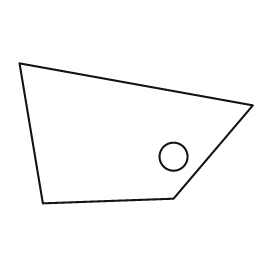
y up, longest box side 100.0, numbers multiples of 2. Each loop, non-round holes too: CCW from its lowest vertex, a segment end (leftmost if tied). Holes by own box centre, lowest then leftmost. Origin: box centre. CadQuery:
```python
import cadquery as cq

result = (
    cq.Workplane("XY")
    .moveTo(-40.0, -30.0)
    .lineTo(16.0, -28.0)
    .lineTo(50.0, 12.0)
    .lineTo(-50.0, 30.0)
    .close()
    .moveTo(16.0, -10.0)
    .circle(6.0)
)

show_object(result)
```